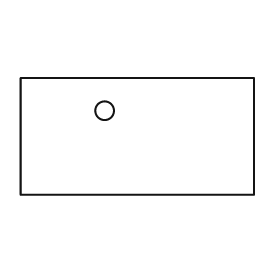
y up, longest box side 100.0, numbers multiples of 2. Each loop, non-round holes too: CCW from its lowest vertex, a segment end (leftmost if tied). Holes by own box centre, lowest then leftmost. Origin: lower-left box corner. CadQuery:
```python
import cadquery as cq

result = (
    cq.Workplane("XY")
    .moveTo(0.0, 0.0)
    .lineTo(100.0, 0.0)
    .lineTo(100.0, 50.0)
    .lineTo(0.0, 50.0)
    .close()
    .moveTo(36.0, 36.0)
    .circle(4.0)
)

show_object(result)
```